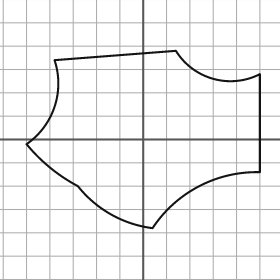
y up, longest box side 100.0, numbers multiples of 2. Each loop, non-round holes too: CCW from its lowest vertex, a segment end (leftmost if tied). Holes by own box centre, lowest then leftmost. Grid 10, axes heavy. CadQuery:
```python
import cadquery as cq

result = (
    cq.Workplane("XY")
    .moveTo(4.0, -38.0)
    .threePointArc((24.0, -20.0), (50.0, -14.0))
    .lineTo(50.0, 28.0)
    .threePointArc((30.0, 26.0), (14.0, 38.0))
    .lineTo(-38.0, 34.0)
    .threePointArc((-38.0, 14.0), (-50.0, -2.0))
    .threePointArc((-40.0, -12.0), (-28.0, -20.0))
    .threePointArc((-14.0, -32.0), (4.0, -38.0))
    .close()
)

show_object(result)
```